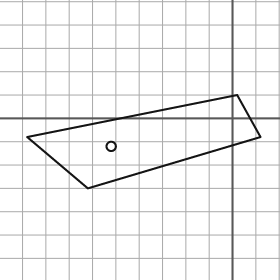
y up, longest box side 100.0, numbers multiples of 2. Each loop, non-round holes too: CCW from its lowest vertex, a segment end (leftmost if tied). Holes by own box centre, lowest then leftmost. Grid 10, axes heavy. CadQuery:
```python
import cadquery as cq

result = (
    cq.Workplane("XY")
    .moveTo(-62.0, -30.0)
    .lineTo(12.0, -8.0)
    .lineTo(2.0, 10.0)
    .lineTo(-88.0, -8.0)
    .close()
    .moveTo(-52.0, -12.0)
    .circle(2.0)
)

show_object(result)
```